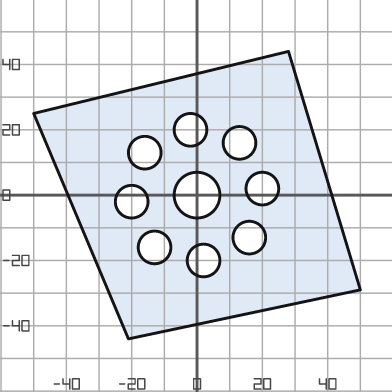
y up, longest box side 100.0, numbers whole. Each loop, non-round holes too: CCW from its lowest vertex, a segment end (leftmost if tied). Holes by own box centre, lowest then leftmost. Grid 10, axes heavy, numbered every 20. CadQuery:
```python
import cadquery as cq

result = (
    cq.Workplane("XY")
    .moveTo(-21.0, -44.0)
    .lineTo(50.0, -29.0)
    .lineTo(28.0, 44.0)
    .lineTo(-50.0, 25.0)
    .close()
    .moveTo(2.0, -20.0)
    .circle(5.0)
    .moveTo(-13.0, -16.0)
    .circle(5.0)
    .moveTo(16.0, -13.0)
    .circle(5.0)
    .moveTo(-20.0, -2.0)
    .circle(5.0)
    .moveTo(0.0, 0.0)
    .circle(7.0)
    .moveTo(20.0, 2.0)
    .circle(5.0)
    .moveTo(-16.0, 13.0)
    .circle(5.0)
    .moveTo(13.0, 16.0)
    .circle(5.0)
    .moveTo(-2.0, 20.0)
    .circle(5.0)
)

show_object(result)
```